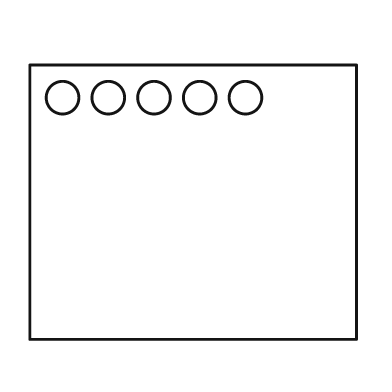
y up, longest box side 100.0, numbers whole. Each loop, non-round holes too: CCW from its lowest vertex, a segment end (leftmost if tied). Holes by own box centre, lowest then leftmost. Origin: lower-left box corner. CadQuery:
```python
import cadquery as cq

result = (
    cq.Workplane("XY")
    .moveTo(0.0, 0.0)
    .lineTo(100.0, 0.0)
    .lineTo(100.0, 84.0)
    .lineTo(0.0, 84.0)
    .close()
    .moveTo(10.0, 74.0)
    .circle(5.0)
    .moveTo(24.0, 74.0)
    .circle(5.0)
    .moveTo(38.0, 74.0)
    .circle(5.0)
    .moveTo(52.0, 74.0)
    .circle(5.0)
    .moveTo(66.0, 74.0)
    .circle(5.0)
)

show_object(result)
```